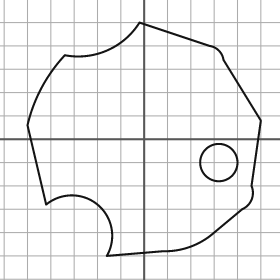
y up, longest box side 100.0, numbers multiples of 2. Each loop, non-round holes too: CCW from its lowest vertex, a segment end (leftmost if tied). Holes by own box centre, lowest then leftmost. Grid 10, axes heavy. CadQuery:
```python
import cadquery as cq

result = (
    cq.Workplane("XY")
    .moveTo(-16.0, -50.0)
    .lineTo(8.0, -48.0)
    .threePointArc((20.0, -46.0), (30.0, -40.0))
    .lineTo(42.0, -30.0)
    .threePointArc((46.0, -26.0), (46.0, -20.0))
    .lineTo(50.0, 8.0)
    .lineTo(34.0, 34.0)
    .threePointArc((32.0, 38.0), (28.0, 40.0))
    .lineTo(-2.0, 50.0)
    .threePointArc((-16.0, 38.0), (-34.0, 36.0))
    .threePointArc((-44.0, 22.0), (-50.0, 6.0))
    .lineTo(-42.0, -28.0)
    .threePointArc((-20.0, -28.0), (-16.0, -50.0))
    .close()
    .moveTo(32.0, -10.0)
    .circle(8.0)
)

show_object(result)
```